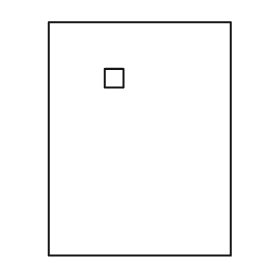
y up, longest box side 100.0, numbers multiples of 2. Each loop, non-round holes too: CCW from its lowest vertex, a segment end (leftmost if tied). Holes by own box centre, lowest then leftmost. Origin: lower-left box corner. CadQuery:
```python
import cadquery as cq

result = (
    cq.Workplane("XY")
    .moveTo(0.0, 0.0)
    .lineTo(78.0, 0.0)
    .lineTo(78.0, 100.0)
    .lineTo(0.0, 100.0)
    .close()
    .moveTo(24.0, 72.0)
    .lineTo(32.0, 72.0)
    .lineTo(32.0, 80.0)
    .lineTo(24.0, 80.0)
    .close()
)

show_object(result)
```